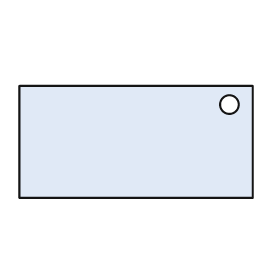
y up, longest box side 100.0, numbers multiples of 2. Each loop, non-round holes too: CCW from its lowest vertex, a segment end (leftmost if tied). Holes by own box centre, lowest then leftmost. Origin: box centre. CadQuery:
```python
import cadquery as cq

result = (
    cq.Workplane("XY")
    .moveTo(-50.0, -24.0)
    .lineTo(50.0, -24.0)
    .lineTo(50.0, 24.0)
    .lineTo(-50.0, 24.0)
    .close()
    .moveTo(40.0, 16.0)
    .circle(4.0)
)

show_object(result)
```